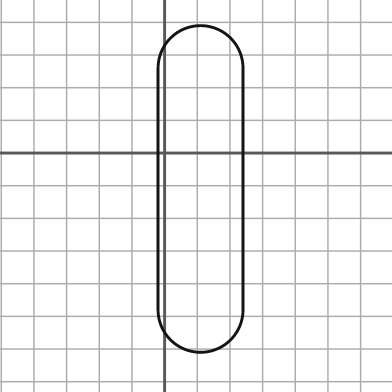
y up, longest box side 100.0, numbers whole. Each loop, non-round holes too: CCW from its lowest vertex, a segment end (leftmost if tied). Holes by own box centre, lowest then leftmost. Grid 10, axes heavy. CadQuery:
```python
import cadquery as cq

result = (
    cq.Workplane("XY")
    .moveTo(-2.0, -48.0)
    .threePointArc((11.0, -61.0), (24.0, -48.0))
    .lineTo(24.0, 26.0)
    .threePointArc((11.0, 39.0), (-2.0, 26.0))
    .close()
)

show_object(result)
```